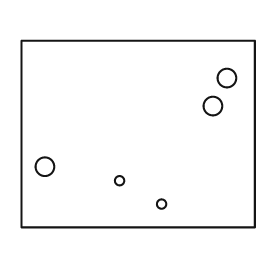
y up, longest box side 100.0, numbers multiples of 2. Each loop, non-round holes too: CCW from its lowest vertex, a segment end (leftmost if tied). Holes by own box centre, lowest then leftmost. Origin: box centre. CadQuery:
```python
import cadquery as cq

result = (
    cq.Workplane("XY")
    .moveTo(-50.0, -40.0)
    .lineTo(50.0, -40.0)
    .lineTo(50.0, 40.0)
    .lineTo(-50.0, 40.0)
    .close()
    .moveTo(10.0, -30.0)
    .circle(2.0)
    .moveTo(-8.0, -20.0)
    .circle(2.0)
    .moveTo(-40.0, -14.0)
    .circle(4.0)
    .moveTo(32.0, 12.0)
    .circle(4.0)
    .moveTo(38.0, 24.0)
    .circle(4.0)
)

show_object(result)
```